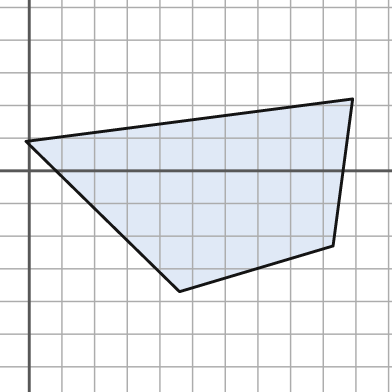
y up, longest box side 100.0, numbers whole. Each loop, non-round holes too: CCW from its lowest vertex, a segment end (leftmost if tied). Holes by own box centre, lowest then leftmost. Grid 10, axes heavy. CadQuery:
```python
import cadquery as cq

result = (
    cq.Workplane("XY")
    .moveTo(46.0, -37.0)
    .lineTo(93.0, -23.0)
    .lineTo(99.0, 22.0)
    .lineTo(-1.0, 9.0)
    .close()
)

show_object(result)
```